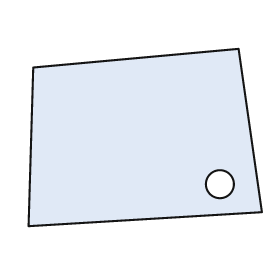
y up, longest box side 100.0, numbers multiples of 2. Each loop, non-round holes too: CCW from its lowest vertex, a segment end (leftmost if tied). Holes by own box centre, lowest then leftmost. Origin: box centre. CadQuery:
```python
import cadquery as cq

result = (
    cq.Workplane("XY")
    .moveTo(-50.0, -38.0)
    .lineTo(50.0, -32.0)
    .lineTo(40.0, 38.0)
    .lineTo(-48.0, 30.0)
    .close()
    .moveTo(32.0, -20.0)
    .circle(6.0)
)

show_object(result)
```